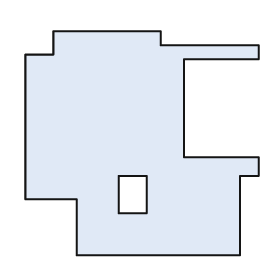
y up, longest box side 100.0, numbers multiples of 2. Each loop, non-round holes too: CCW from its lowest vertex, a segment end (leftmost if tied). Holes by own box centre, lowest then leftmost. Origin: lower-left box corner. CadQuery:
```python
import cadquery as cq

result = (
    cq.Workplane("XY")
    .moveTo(22.0, 0.0)
    .lineTo(92.0, 0.0)
    .lineTo(92.0, 34.0)
    .lineTo(100.0, 34.0)
    .lineTo(100.0, 42.0)
    .lineTo(68.0, 42.0)
    .lineTo(68.0, 84.0)
    .lineTo(100.0, 84.0)
    .lineTo(100.0, 90.0)
    .lineTo(58.0, 90.0)
    .lineTo(58.0, 96.0)
    .lineTo(12.0, 96.0)
    .lineTo(12.0, 86.0)
    .lineTo(0.0, 86.0)
    .lineTo(0.0, 24.0)
    .lineTo(22.0, 24.0)
    .close()
    .moveTo(40.0, 18.0)
    .lineTo(52.0, 18.0)
    .lineTo(52.0, 34.0)
    .lineTo(40.0, 34.0)
    .close()
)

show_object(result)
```